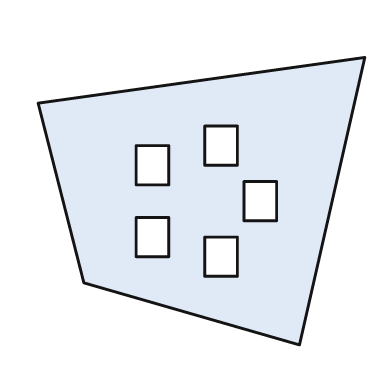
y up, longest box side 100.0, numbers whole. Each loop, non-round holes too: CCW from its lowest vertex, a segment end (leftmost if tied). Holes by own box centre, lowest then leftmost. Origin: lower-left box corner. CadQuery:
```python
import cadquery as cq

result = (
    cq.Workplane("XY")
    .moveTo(80.0, 0.0)
    .lineTo(100.0, 88.0)
    .lineTo(0.0, 74.0)
    .lineTo(14.0, 19.0)
    .close()
    .moveTo(51.0, 21.0)
    .lineTo(61.0, 21.0)
    .lineTo(61.0, 33.0)
    .lineTo(51.0, 33.0)
    .close()
    .moveTo(30.0, 27.0)
    .lineTo(40.0, 27.0)
    .lineTo(40.0, 39.0)
    .lineTo(30.0, 39.0)
    .close()
    .moveTo(63.0, 38.0)
    .lineTo(73.0, 38.0)
    .lineTo(73.0, 50.0)
    .lineTo(63.0, 50.0)
    .close()
    .moveTo(30.0, 49.0)
    .lineTo(40.0, 49.0)
    .lineTo(40.0, 61.0)
    .lineTo(30.0, 61.0)
    .close()
    .moveTo(51.0, 55.0)
    .lineTo(61.0, 55.0)
    .lineTo(61.0, 67.0)
    .lineTo(51.0, 67.0)
    .close()
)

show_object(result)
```